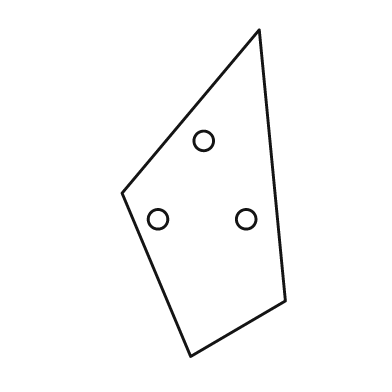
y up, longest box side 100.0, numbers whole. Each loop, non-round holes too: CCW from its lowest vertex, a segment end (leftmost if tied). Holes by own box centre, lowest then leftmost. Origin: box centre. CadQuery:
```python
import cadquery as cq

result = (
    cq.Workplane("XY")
    .moveTo(-4.0, -50.0)
    .lineTo(25.0, -33.0)
    .lineTo(17.0, 50.0)
    .lineTo(-25.0, 0.0)
    .close()
    .moveTo(-14.0, -8.0)
    .circle(3.0)
    .moveTo(13.0, -8.0)
    .circle(3.0)
    .moveTo(0.0, 16.0)
    .circle(3.0)
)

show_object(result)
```